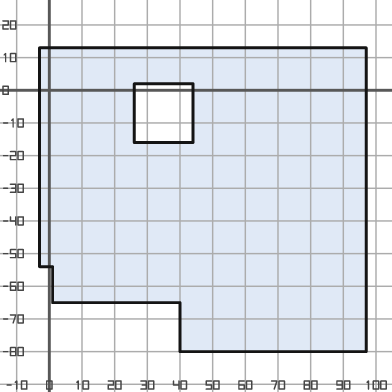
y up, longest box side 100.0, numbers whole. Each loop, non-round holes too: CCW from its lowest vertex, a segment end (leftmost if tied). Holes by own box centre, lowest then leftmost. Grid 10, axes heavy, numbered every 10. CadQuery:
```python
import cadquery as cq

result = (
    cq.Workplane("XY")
    .moveTo(40.0, -80.0)
    .lineTo(97.0, -80.0)
    .lineTo(97.0, 13.0)
    .lineTo(-3.0, 13.0)
    .lineTo(-3.0, -54.0)
    .lineTo(1.0, -54.0)
    .lineTo(1.0, -65.0)
    .lineTo(40.0, -65.0)
    .close()
    .moveTo(26.0, -16.0)
    .lineTo(44.0, -16.0)
    .lineTo(44.0, 2.0)
    .lineTo(26.0, 2.0)
    .close()
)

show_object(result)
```